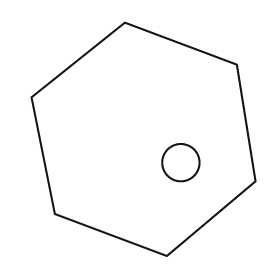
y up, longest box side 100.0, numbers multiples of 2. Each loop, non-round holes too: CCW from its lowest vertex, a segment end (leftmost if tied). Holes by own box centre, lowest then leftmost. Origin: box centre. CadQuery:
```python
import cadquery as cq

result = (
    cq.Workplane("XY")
    .moveTo(10.0, -50.0)
    .lineTo(48.0, -18.0)
    .lineTo(40.0, 32.0)
    .lineTo(-8.0, 50.0)
    .lineTo(-48.0, 18.0)
    .lineTo(-38.0, -32.0)
    .close()
    .moveTo(16.0, -10.0)
    .circle(8.0)
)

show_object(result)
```